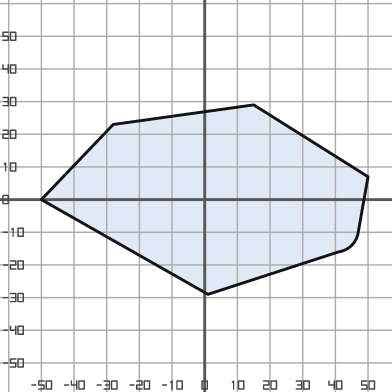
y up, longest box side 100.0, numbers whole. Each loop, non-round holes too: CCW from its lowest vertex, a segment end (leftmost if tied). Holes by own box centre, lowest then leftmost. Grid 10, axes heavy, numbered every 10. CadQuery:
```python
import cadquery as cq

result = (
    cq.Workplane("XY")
    .moveTo(1.0, -29.0)
    .lineTo(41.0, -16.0)
    .threePointArc((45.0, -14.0), (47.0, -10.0))
    .lineTo(50.0, 7.0)
    .lineTo(15.0, 29.0)
    .lineTo(-28.0, 23.0)
    .lineTo(-50.0, 0.0)
    .close()
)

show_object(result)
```